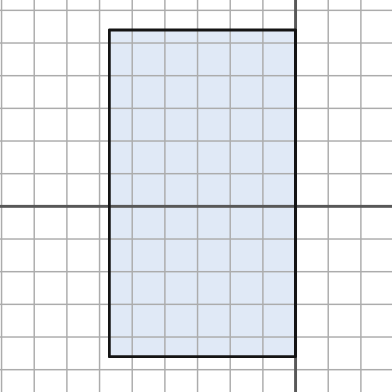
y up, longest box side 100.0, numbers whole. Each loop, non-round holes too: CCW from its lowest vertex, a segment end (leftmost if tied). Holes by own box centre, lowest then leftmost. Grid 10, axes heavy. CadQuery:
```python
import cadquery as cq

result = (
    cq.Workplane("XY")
    .moveTo(-57.0, -46.0)
    .lineTo(0.0, -46.0)
    .lineTo(0.0, 54.0)
    .lineTo(-57.0, 54.0)
    .close()
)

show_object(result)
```